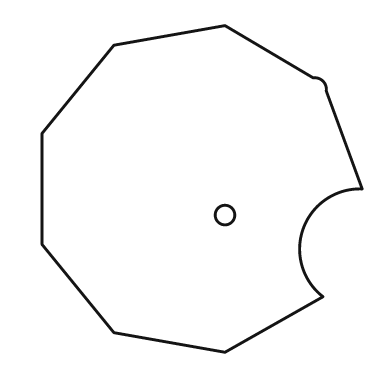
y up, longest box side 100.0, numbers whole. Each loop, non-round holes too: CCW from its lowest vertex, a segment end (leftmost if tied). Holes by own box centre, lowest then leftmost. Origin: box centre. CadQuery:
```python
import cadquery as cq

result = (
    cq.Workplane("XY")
    .moveTo(7.0, -50.0)
    .lineTo(37.0, -33.0)
    .threePointArc((31.0, -12.0), (49.0, 0.0))
    .lineTo(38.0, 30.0)
    .threePointArc((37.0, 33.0), (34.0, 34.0))
    .lineTo(7.0, 50.0)
    .lineTo(-27.0, 44.0)
    .lineTo(-49.0, 17.0)
    .lineTo(-49.0, -17.0)
    .lineTo(-27.0, -44.0)
    .close()
    .moveTo(7.0, -8.0)
    .circle(3.0)
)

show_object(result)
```